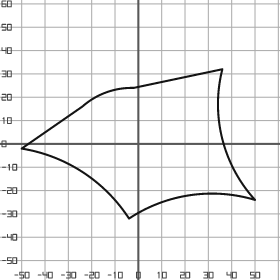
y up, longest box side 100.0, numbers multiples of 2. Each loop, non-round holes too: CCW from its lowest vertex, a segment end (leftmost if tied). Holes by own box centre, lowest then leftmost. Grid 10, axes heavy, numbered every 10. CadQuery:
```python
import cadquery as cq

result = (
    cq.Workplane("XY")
    .moveTo(-4.0, -32.0)
    .threePointArc((22.0, -22.0), (50.0, -24.0))
    .threePointArc((36.0, 2.0), (36.0, 32.0))
    .lineTo(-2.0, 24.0)
    .threePointArc((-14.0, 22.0), (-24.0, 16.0))
    .lineTo(-50.0, -2.0)
    .threePointArc((-24.0, -12.0), (-4.0, -32.0))
    .close()
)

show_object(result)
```